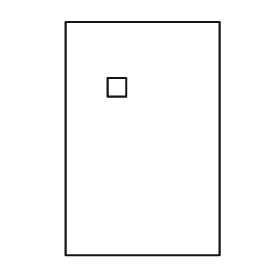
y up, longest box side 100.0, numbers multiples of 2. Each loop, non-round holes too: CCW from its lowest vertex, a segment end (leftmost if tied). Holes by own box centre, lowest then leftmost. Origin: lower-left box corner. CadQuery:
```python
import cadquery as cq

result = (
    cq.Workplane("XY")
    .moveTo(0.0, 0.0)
    .lineTo(66.0, 0.0)
    .lineTo(66.0, 100.0)
    .lineTo(0.0, 100.0)
    .close()
    .moveTo(18.0, 68.0)
    .lineTo(26.0, 68.0)
    .lineTo(26.0, 76.0)
    .lineTo(18.0, 76.0)
    .close()
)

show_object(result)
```